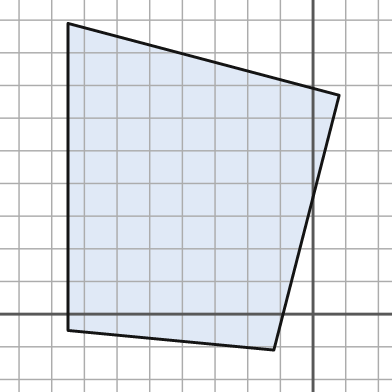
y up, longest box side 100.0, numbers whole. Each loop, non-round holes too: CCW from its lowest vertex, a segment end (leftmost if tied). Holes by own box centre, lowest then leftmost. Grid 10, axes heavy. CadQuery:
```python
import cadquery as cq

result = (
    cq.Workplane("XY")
    .moveTo(-12.0, -11.0)
    .lineTo(8.0, 67.0)
    .lineTo(-75.0, 89.0)
    .lineTo(-75.0, -5.0)
    .close()
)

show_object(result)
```